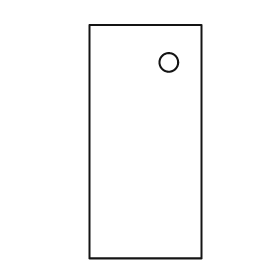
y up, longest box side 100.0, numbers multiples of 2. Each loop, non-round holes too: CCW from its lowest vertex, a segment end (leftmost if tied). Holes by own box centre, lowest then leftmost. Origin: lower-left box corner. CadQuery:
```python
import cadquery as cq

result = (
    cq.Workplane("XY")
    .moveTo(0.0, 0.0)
    .lineTo(48.0, 0.0)
    .lineTo(48.0, 100.0)
    .lineTo(0.0, 100.0)
    .close()
    .moveTo(34.0, 84.0)
    .circle(4.0)
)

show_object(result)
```